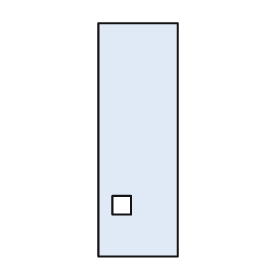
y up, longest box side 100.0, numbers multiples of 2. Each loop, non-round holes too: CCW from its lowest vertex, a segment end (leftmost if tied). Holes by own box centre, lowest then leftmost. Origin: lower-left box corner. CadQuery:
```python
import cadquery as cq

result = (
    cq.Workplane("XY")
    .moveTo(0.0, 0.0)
    .lineTo(34.0, 0.0)
    .lineTo(34.0, 100.0)
    .lineTo(0.0, 100.0)
    .close()
    .moveTo(6.0, 18.0)
    .lineTo(14.0, 18.0)
    .lineTo(14.0, 26.0)
    .lineTo(6.0, 26.0)
    .close()
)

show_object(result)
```